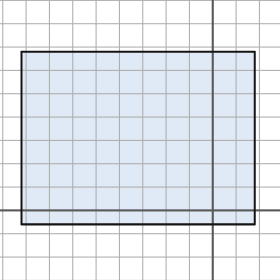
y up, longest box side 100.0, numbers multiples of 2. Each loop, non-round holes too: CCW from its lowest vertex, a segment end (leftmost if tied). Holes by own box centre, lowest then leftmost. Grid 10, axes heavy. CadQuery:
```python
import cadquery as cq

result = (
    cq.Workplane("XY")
    .moveTo(-82.0, -6.0)
    .lineTo(18.0, -6.0)
    .lineTo(18.0, 68.0)
    .lineTo(-82.0, 68.0)
    .close()
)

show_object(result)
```